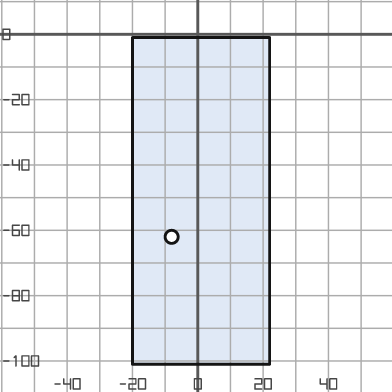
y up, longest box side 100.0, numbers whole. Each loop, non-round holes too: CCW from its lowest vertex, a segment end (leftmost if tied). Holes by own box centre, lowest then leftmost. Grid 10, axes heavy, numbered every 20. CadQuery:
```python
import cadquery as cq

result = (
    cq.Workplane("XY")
    .moveTo(-20.0, -101.0)
    .lineTo(22.0, -101.0)
    .lineTo(22.0, -1.0)
    .lineTo(-20.0, -1.0)
    .close()
    .moveTo(-8.0, -62.0)
    .circle(2.0)
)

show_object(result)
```